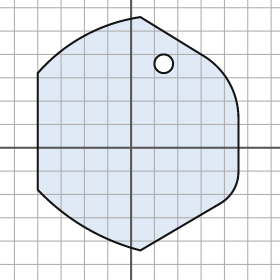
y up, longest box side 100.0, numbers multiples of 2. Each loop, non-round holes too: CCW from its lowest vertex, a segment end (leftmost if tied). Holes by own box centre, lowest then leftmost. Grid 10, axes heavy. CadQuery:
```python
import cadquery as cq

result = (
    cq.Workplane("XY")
    .moveTo(4.0, -44.0)
    .lineTo(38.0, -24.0)
    .threePointArc((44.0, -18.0), (46.0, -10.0))
    .lineTo(46.0, 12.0)
    .threePointArc((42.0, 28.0), (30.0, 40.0))
    .lineTo(4.0, 56.0)
    .threePointArc((-20.0, 48.0), (-40.0, 32.0))
    .lineTo(-40.0, -18.0)
    .threePointArc((-20.0, -34.0), (4.0, -44.0))
    .close()
    .moveTo(14.0, 36.0)
    .circle(4.0)
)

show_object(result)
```